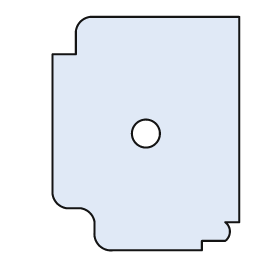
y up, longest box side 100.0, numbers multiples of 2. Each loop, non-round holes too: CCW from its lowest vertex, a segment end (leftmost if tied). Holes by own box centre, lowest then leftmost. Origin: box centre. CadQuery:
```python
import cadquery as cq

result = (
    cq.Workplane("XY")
    .moveTo(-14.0, -50.0)
    .lineTo(24.0, -50.0)
    .lineTo(24.0, -46.0)
    .lineTo(34.0, -46.0)
    .threePointArc((36.0, -42.0), (34.0, -38.0))
    .lineTo(40.0, -38.0)
    .lineTo(40.0, 50.0)
    .lineTo(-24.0, 50.0)
    .threePointArc((-28.0, 48.0), (-30.0, 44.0))
    .lineTo(-30.0, 34.0)
    .lineTo(-40.0, 34.0)
    .lineTo(-40.0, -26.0)
    .threePointArc((-38.0, -30.0), (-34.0, -32.0))
    .lineTo(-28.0, -32.0)
    .threePointArc((-24.0, -34.0), (-22.0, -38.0))
    .lineTo(-22.0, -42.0)
    .threePointArc((-20.0, -48.0), (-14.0, -50.0))
    .close()
    .moveTo(0.0, 0.0)
    .circle(6.0)
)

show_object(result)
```